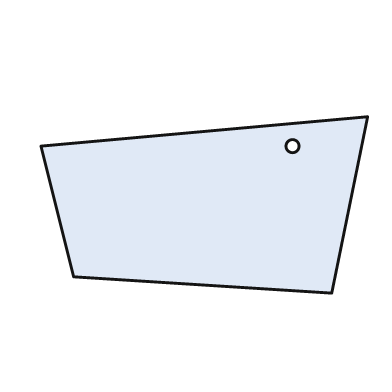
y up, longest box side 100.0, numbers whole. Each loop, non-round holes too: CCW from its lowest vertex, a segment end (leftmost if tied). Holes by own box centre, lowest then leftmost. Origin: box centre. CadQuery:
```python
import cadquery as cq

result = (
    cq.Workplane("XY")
    .moveTo(39.0, -27.0)
    .lineTo(50.0, 27.0)
    .lineTo(-50.0, 18.0)
    .lineTo(-40.0, -22.0)
    .close()
    .moveTo(27.0, 18.0)
    .circle(2.0)
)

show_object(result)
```